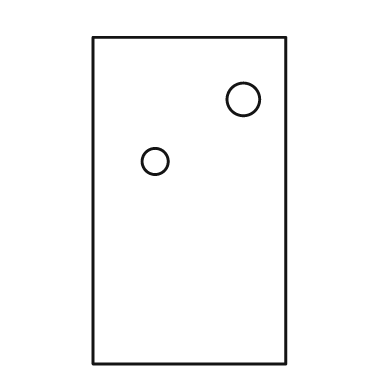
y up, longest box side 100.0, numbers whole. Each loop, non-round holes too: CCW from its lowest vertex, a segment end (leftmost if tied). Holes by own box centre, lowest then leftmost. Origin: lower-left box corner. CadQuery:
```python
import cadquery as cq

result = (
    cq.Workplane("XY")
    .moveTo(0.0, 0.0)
    .lineTo(59.0, 0.0)
    .lineTo(59.0, 100.0)
    .lineTo(0.0, 100.0)
    .close()
    .moveTo(19.0, 62.0)
    .circle(4.0)
    .moveTo(46.0, 81.0)
    .circle(5.0)
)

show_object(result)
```